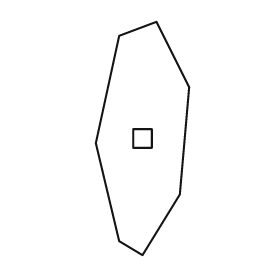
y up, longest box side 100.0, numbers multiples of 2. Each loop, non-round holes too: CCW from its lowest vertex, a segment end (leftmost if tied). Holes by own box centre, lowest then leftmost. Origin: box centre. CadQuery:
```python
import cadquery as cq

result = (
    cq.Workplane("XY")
    .moveTo(0.0, -50.0)
    .lineTo(16.0, -24.0)
    .lineTo(20.0, 22.0)
    .lineTo(6.0, 50.0)
    .lineTo(-10.0, 44.0)
    .lineTo(-20.0, -2.0)
    .lineTo(-10.0, -44.0)
    .close()
    .moveTo(-4.0, -4.0)
    .lineTo(4.0, -4.0)
    .lineTo(4.0, 4.0)
    .lineTo(-4.0, 4.0)
    .close()
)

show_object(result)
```